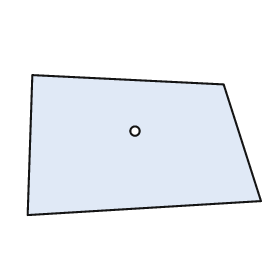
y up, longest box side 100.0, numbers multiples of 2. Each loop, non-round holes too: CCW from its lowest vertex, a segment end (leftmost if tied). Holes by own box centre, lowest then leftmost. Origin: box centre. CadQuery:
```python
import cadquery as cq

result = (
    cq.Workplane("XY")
    .moveTo(-50.0, -30.0)
    .lineTo(50.0, -24.0)
    .lineTo(34.0, 26.0)
    .lineTo(-48.0, 30.0)
    .close()
    .moveTo(-4.0, 6.0)
    .circle(2.0)
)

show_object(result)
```